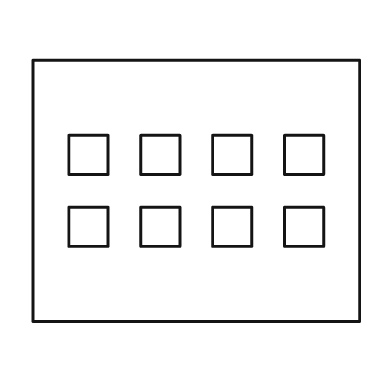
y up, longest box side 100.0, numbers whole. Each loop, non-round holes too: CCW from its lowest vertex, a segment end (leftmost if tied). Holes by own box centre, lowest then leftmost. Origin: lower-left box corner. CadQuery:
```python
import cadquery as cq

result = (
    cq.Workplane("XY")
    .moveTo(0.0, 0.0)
    .lineTo(100.0, 0.0)
    .lineTo(100.0, 80.0)
    .lineTo(0.0, 80.0)
    .close()
    .moveTo(11.0, 23.0)
    .lineTo(23.0, 23.0)
    .lineTo(23.0, 35.0)
    .lineTo(11.0, 35.0)
    .close()
    .moveTo(33.0, 23.0)
    .lineTo(45.0, 23.0)
    .lineTo(45.0, 35.0)
    .lineTo(33.0, 35.0)
    .close()
    .moveTo(55.0, 23.0)
    .lineTo(67.0, 23.0)
    .lineTo(67.0, 35.0)
    .lineTo(55.0, 35.0)
    .close()
    .moveTo(77.0, 23.0)
    .lineTo(89.0, 23.0)
    .lineTo(89.0, 35.0)
    .lineTo(77.0, 35.0)
    .close()
    .moveTo(11.0, 45.0)
    .lineTo(23.0, 45.0)
    .lineTo(23.0, 57.0)
    .lineTo(11.0, 57.0)
    .close()
    .moveTo(33.0, 45.0)
    .lineTo(45.0, 45.0)
    .lineTo(45.0, 57.0)
    .lineTo(33.0, 57.0)
    .close()
    .moveTo(55.0, 45.0)
    .lineTo(67.0, 45.0)
    .lineTo(67.0, 57.0)
    .lineTo(55.0, 57.0)
    .close()
    .moveTo(77.0, 45.0)
    .lineTo(89.0, 45.0)
    .lineTo(89.0, 57.0)
    .lineTo(77.0, 57.0)
    .close()
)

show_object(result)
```